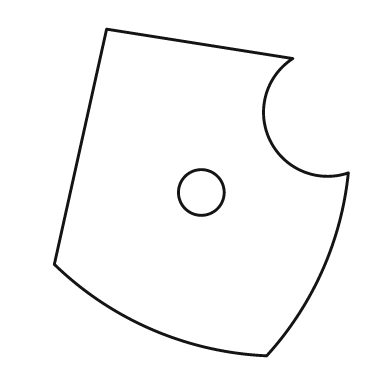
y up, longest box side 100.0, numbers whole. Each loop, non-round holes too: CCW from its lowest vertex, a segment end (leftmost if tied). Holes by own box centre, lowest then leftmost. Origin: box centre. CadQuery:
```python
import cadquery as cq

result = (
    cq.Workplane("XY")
    .moveTo(20.0, -50.0)
    .threePointArc((37.0, -24.0), (45.0, 6.0))
    .threePointArc((21.0, 16.0), (28.0, 41.0))
    .lineTo(-29.0, 50.0)
    .lineTo(-45.0, -22.0)
    .threePointArc((-15.0, -42.0), (20.0, -50.0))
    .close()
    .moveTo(0.0, 0.0)
    .circle(7.0)
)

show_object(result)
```